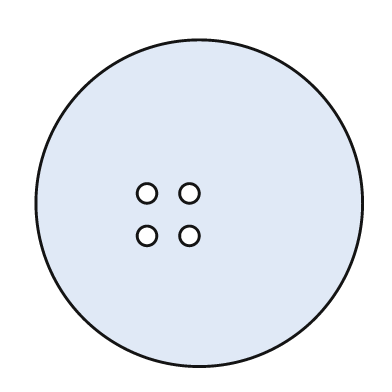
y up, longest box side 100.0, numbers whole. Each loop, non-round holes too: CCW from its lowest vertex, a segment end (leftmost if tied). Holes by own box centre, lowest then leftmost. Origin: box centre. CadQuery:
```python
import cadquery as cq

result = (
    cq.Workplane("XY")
    .moveTo(0.0, 0.0)
    .circle(50.0)
    .moveTo(-16.0, -10.0)
    .circle(3.0)
    .moveTo(-3.0, -10.0)
    .circle(3.0)
    .moveTo(-16.0, 3.0)
    .circle(3.0)
    .moveTo(-3.0, 3.0)
    .circle(3.0)
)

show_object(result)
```